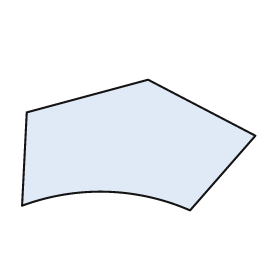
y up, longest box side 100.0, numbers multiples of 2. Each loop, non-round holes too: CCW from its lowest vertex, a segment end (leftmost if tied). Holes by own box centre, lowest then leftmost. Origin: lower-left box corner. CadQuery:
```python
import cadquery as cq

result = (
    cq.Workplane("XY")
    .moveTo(72.0, 0.0)
    .lineTo(100.0, 32.0)
    .lineTo(54.0, 56.0)
    .lineTo(2.0, 42.0)
    .lineTo(0.0, 2.0)
    .threePointArc((36.0, 8.0), (72.0, 0.0))
    .close()
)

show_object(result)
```